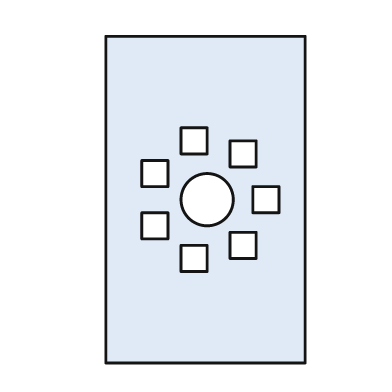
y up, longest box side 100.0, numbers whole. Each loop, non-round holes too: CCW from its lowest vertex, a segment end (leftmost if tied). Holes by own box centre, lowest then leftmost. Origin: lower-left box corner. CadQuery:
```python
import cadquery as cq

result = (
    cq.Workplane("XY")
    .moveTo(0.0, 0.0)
    .lineTo(61.0, 0.0)
    .lineTo(61.0, 100.0)
    .lineTo(0.0, 100.0)
    .close()
    .moveTo(23.0, 28.0)
    .lineTo(31.0, 28.0)
    .lineTo(31.0, 36.0)
    .lineTo(23.0, 36.0)
    .close()
    .moveTo(38.0, 32.0)
    .lineTo(46.0, 32.0)
    .lineTo(46.0, 40.0)
    .lineTo(38.0, 40.0)
    .close()
    .moveTo(11.0, 38.0)
    .lineTo(19.0, 38.0)
    .lineTo(19.0, 46.0)
    .lineTo(11.0, 46.0)
    .close()
    .moveTo(31.0, 50.0)
    .circle(8.0)
    .moveTo(45.0, 46.0)
    .lineTo(53.0, 46.0)
    .lineTo(53.0, 54.0)
    .lineTo(45.0, 54.0)
    .close()
    .moveTo(11.0, 54.0)
    .lineTo(19.0, 54.0)
    .lineTo(19.0, 62.0)
    .lineTo(11.0, 62.0)
    .close()
    .moveTo(38.0, 60.0)
    .lineTo(46.0, 60.0)
    .lineTo(46.0, 68.0)
    .lineTo(38.0, 68.0)
    .close()
    .moveTo(23.0, 64.0)
    .lineTo(31.0, 64.0)
    .lineTo(31.0, 72.0)
    .lineTo(23.0, 72.0)
    .close()
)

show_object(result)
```